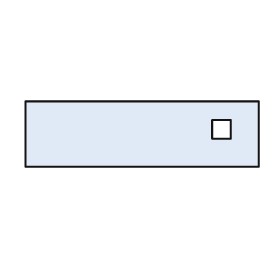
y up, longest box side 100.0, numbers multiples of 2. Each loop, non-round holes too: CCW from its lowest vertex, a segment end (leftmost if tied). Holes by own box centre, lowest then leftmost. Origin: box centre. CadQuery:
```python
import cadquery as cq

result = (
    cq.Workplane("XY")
    .moveTo(-50.0, -14.0)
    .lineTo(50.0, -14.0)
    .lineTo(50.0, 14.0)
    .lineTo(-50.0, 14.0)
    .close()
    .moveTo(30.0, -2.0)
    .lineTo(38.0, -2.0)
    .lineTo(38.0, 6.0)
    .lineTo(30.0, 6.0)
    .close()
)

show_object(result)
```